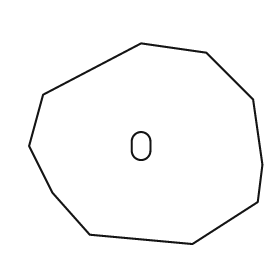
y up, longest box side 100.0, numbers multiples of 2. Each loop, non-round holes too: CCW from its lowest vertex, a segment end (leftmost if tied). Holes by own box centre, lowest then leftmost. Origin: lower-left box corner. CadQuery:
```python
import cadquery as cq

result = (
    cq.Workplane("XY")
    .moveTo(70.0, 0.0)
    .lineTo(98.0, 18.0)
    .lineTo(100.0, 34.0)
    .lineTo(96.0, 62.0)
    .lineTo(76.0, 82.0)
    .lineTo(48.0, 86.0)
    .lineTo(6.0, 64.0)
    .lineTo(0.0, 42.0)
    .lineTo(10.0, 22.0)
    .lineTo(26.0, 4.0)
    .close()
    .moveTo(44.0, 40.0)
    .threePointArc((48.0, 36.0), (52.0, 40.0))
    .lineTo(52.0, 44.0)
    .threePointArc((48.0, 48.0), (44.0, 44.0))
    .close()
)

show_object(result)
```